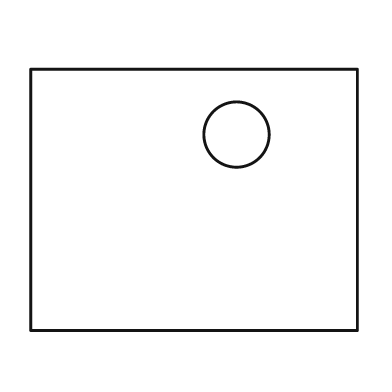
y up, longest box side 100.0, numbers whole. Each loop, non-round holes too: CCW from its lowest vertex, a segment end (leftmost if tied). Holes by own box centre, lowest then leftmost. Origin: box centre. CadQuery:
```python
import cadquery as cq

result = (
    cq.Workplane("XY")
    .moveTo(-50.0, -40.0)
    .lineTo(50.0, -40.0)
    .lineTo(50.0, 40.0)
    .lineTo(-50.0, 40.0)
    .close()
    .moveTo(13.0, 20.0)
    .circle(10.0)
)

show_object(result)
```